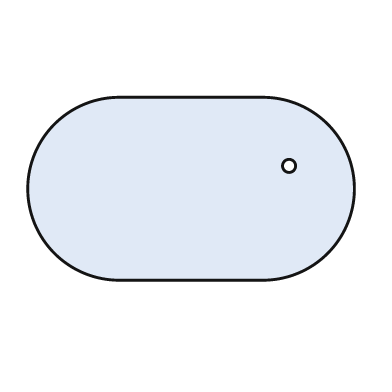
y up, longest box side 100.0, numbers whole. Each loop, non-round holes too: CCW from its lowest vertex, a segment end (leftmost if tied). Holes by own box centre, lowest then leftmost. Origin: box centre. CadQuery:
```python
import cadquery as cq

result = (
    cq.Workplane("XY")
    .moveTo(-22.0, -28.0)
    .lineTo(22.0, -28.0)
    .threePointArc((50.0, 0.0), (22.0, 28.0))
    .lineTo(-22.0, 28.0)
    .threePointArc((-50.0, 0.0), (-22.0, -28.0))
    .close()
    .moveTo(30.0, 7.0)
    .circle(2.0)
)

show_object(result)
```